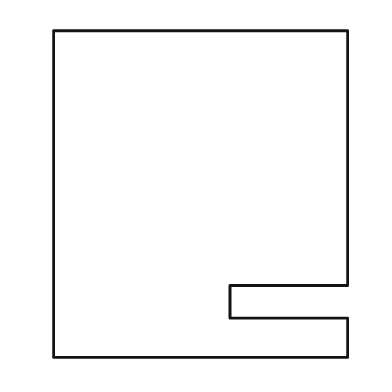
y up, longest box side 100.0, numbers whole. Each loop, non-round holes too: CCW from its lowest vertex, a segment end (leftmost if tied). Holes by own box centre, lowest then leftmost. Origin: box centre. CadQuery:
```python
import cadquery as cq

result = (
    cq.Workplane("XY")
    .moveTo(-45.0, -50.0)
    .lineTo(45.0, -50.0)
    .lineTo(45.0, -38.0)
    .lineTo(9.0, -38.0)
    .lineTo(9.0, -28.0)
    .lineTo(45.0, -28.0)
    .lineTo(45.0, 50.0)
    .lineTo(-45.0, 50.0)
    .close()
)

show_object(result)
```